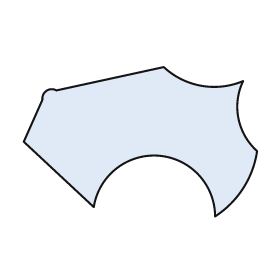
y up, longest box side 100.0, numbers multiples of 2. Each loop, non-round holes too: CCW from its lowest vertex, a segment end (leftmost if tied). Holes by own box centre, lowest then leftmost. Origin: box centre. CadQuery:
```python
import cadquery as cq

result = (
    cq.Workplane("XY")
    .moveTo(32.0, -32.0)
    .threePointArc((44.0, -20.0), (50.0, -4.0))
    .threePointArc((42.0, 10.0), (44.0, 26.0))
    .threePointArc((26.0, 24.0), (10.0, 32.0))
    .lineTo(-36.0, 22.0)
    .threePointArc((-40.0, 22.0), (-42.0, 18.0))
    .lineTo(-50.0, 0.0)
    .lineTo(-20.0, -28.0)
    .threePointArc((8.0, -6.0), (32.0, -32.0))
    .close()
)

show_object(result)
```